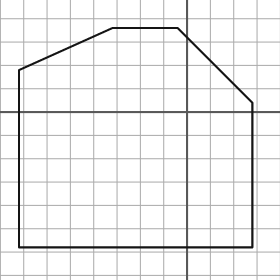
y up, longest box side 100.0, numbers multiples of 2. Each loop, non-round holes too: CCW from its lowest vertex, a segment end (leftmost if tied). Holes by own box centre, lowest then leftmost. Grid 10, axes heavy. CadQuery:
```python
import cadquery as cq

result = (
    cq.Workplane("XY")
    .moveTo(-72.0, -58.0)
    .lineTo(28.0, -58.0)
    .lineTo(28.0, 4.0)
    .lineTo(-4.0, 36.0)
    .lineTo(-32.0, 36.0)
    .lineTo(-72.0, 18.0)
    .close()
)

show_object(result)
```